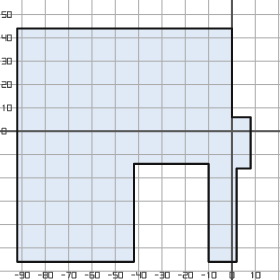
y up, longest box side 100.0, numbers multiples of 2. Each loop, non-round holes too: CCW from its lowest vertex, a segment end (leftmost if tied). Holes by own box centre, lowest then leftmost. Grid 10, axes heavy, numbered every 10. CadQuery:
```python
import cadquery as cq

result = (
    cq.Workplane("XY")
    .moveTo(-92.0, -56.0)
    .lineTo(-42.0, -56.0)
    .lineTo(-42.0, -14.0)
    .lineTo(-10.0, -14.0)
    .lineTo(-10.0, -56.0)
    .lineTo(2.0, -56.0)
    .lineTo(2.0, -16.0)
    .lineTo(8.0, -16.0)
    .lineTo(8.0, 6.0)
    .lineTo(0.0, 6.0)
    .lineTo(0.0, 44.0)
    .lineTo(-92.0, 44.0)
    .close()
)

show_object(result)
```